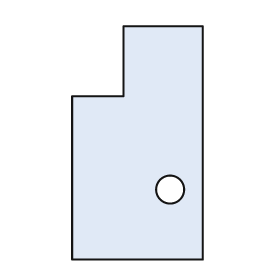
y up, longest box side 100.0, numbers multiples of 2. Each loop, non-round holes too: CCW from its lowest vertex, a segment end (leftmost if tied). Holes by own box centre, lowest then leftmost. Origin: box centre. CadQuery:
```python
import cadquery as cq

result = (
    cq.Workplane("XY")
    .moveTo(-28.0, -50.0)
    .lineTo(28.0, -50.0)
    .lineTo(28.0, 50.0)
    .lineTo(-6.0, 50.0)
    .lineTo(-6.0, 20.0)
    .lineTo(-28.0, 20.0)
    .close()
    .moveTo(14.0, -20.0)
    .circle(6.0)
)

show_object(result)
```